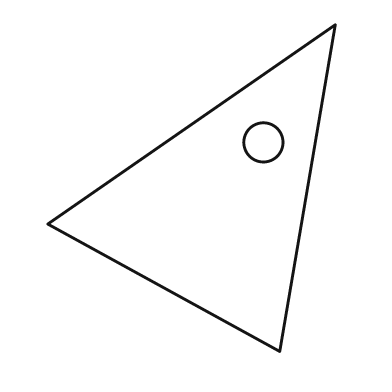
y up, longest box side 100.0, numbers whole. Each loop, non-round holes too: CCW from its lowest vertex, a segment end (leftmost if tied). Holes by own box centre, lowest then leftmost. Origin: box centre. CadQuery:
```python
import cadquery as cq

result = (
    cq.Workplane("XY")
    .moveTo(27.0, -50.0)
    .lineTo(44.0, 50.0)
    .lineTo(-44.0, -11.0)
    .close()
    .moveTo(22.0, 14.0)
    .circle(6.0)
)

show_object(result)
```